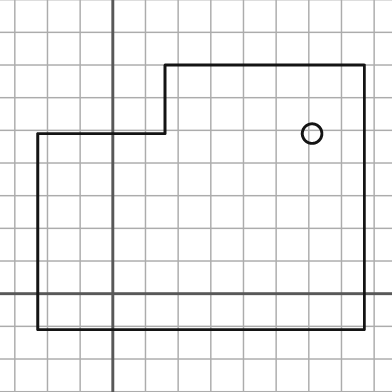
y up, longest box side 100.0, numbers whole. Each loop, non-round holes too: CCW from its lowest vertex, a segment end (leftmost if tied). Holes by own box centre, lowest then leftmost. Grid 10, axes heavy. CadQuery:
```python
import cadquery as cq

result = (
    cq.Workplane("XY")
    .moveTo(-23.0, -11.0)
    .lineTo(77.0, -11.0)
    .lineTo(77.0, 70.0)
    .lineTo(16.0, 70.0)
    .lineTo(16.0, 49.0)
    .lineTo(-23.0, 49.0)
    .close()
    .moveTo(61.0, 49.0)
    .circle(3.0)
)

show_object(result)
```